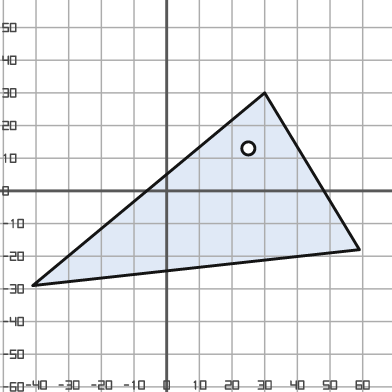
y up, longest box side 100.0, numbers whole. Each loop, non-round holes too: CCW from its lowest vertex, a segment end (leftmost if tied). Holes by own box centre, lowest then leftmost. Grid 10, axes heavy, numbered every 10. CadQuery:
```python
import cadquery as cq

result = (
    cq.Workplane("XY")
    .moveTo(-41.0, -29.0)
    .lineTo(59.0, -18.0)
    .lineTo(30.0, 30.0)
    .close()
    .moveTo(25.0, 13.0)
    .circle(2.0)
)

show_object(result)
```